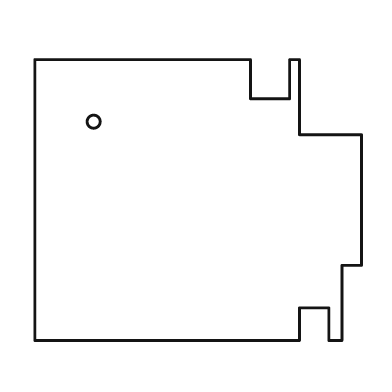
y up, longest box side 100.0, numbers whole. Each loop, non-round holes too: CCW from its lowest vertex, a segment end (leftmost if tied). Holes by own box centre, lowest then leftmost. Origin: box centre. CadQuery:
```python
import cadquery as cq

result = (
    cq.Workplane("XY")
    .moveTo(-50.0, -43.0)
    .lineTo(31.0, -43.0)
    .lineTo(31.0, -33.0)
    .lineTo(40.0, -33.0)
    .lineTo(40.0, -43.0)
    .lineTo(44.0, -43.0)
    .lineTo(44.0, -20.0)
    .lineTo(50.0, -20.0)
    .lineTo(50.0, 20.0)
    .lineTo(31.0, 20.0)
    .lineTo(31.0, 43.0)
    .lineTo(28.0, 43.0)
    .lineTo(28.0, 31.0)
    .lineTo(16.0, 31.0)
    .lineTo(16.0, 43.0)
    .lineTo(-50.0, 43.0)
    .close()
    .moveTo(-32.0, 24.0)
    .circle(2.0)
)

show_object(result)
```